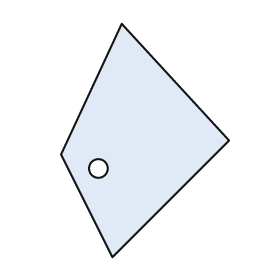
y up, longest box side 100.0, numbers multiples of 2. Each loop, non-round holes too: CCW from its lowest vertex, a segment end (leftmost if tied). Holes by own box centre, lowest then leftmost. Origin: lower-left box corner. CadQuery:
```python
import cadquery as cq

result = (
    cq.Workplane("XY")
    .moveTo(22.0, 0.0)
    .lineTo(72.0, 50.0)
    .lineTo(26.0, 100.0)
    .lineTo(0.0, 44.0)
    .close()
    .moveTo(16.0, 38.0)
    .circle(4.0)
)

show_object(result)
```